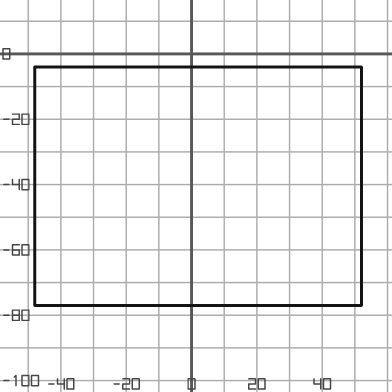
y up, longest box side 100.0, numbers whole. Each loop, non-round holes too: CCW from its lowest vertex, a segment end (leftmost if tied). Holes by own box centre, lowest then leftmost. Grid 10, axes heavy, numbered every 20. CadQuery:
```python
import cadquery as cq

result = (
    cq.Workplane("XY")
    .moveTo(-48.0, -77.0)
    .lineTo(52.0, -77.0)
    .lineTo(52.0, -4.0)
    .lineTo(-48.0, -4.0)
    .close()
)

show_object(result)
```